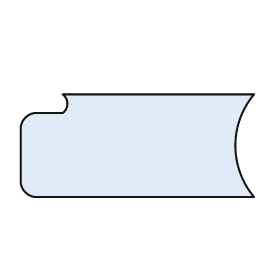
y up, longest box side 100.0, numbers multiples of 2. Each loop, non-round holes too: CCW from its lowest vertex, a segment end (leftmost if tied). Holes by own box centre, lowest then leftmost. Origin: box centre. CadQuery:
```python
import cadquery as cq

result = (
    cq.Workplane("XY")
    .moveTo(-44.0, -22.0)
    .lineTo(50.0, -22.0)
    .threePointArc((42.0, 0.0), (50.0, 22.0))
    .lineTo(-32.0, 22.0)
    .threePointArc((-30.0, 18.0), (-32.0, 14.0))
    .lineTo(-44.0, 14.0)
    .threePointArc((-48.0, 12.0), (-50.0, 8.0))
    .lineTo(-50.0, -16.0)
    .threePointArc((-48.0, -20.0), (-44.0, -22.0))
    .close()
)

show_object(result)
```